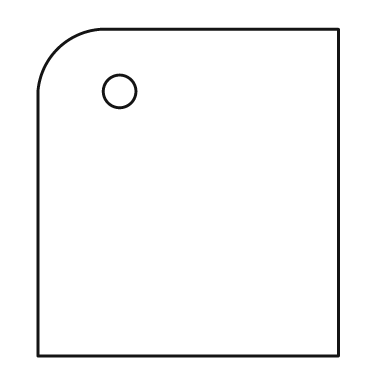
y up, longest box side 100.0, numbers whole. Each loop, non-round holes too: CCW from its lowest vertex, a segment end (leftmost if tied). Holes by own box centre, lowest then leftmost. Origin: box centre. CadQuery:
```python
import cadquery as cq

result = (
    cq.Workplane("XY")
    .moveTo(-46.0, -50.0)
    .lineTo(46.0, -50.0)
    .lineTo(46.0, 50.0)
    .lineTo(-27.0, 50.0)
    .threePointArc((-40.0, 44.0), (-46.0, 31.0))
    .close()
    .moveTo(-21.0, 31.0)
    .circle(5.0)
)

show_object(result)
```